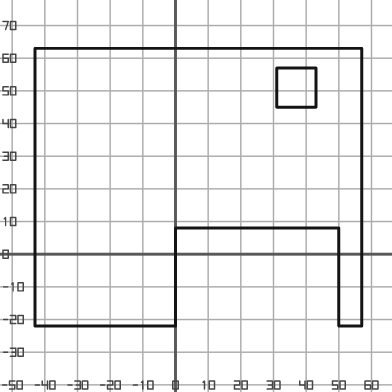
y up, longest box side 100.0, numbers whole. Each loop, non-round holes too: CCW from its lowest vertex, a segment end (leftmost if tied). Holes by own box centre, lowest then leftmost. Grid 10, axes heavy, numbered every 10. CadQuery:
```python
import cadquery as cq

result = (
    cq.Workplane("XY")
    .moveTo(-43.0, -22.0)
    .lineTo(0.0, -22.0)
    .lineTo(0.0, 8.0)
    .lineTo(50.0, 8.0)
    .lineTo(50.0, -22.0)
    .lineTo(57.0, -22.0)
    .lineTo(57.0, 63.0)
    .lineTo(-43.0, 63.0)
    .close()
    .moveTo(31.0, 45.0)
    .lineTo(43.0, 45.0)
    .lineTo(43.0, 57.0)
    .lineTo(31.0, 57.0)
    .close()
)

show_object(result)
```